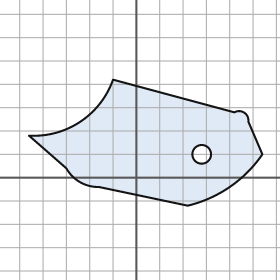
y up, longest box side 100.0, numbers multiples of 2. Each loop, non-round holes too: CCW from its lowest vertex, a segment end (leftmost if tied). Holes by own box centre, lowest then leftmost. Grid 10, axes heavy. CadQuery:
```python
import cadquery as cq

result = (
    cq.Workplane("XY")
    .moveTo(22.0, -12.0)
    .threePointArc((40.0, -4.0), (54.0, 10.0))
    .lineTo(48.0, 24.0)
    .threePointArc((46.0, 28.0), (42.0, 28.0))
    .lineTo(-10.0, 42.0)
    .threePointArc((-24.0, 24.0), (-46.0, 18.0))
    .lineTo(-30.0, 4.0)
    .threePointArc((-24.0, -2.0), (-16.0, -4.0))
    .close()
    .moveTo(28.0, 10.0)
    .circle(4.0)
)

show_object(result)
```